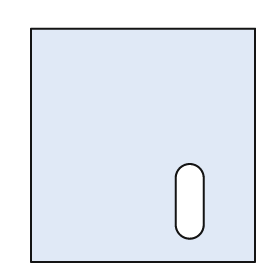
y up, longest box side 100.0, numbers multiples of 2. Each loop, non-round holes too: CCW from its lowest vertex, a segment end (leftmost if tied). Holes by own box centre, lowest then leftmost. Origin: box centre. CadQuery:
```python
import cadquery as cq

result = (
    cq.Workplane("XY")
    .moveTo(-48.0, -50.0)
    .lineTo(48.0, -50.0)
    .lineTo(48.0, 50.0)
    .lineTo(-48.0, 50.0)
    .close()
    .moveTo(14.0, -34.0)
    .threePointArc((20.0, -40.0), (26.0, -34.0))
    .lineTo(26.0, -14.0)
    .threePointArc((20.0, -8.0), (14.0, -14.0))
    .close()
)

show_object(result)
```